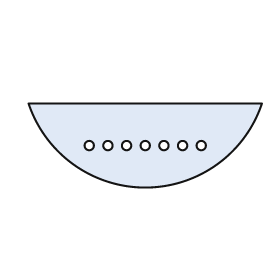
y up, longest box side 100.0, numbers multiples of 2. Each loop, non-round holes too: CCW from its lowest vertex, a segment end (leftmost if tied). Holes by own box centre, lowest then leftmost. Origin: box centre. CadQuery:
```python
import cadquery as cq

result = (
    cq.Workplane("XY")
    .moveTo(-50.0, 18.0)
    .threePointArc((0.0, -18.0), (50.0, 18.0))
    .close()
    .moveTo(-24.0, 0.0)
    .circle(2.0)
    .moveTo(-16.0, 0.0)
    .circle(2.0)
    .moveTo(-8.0, 0.0)
    .circle(2.0)
    .moveTo(0.0, 0.0)
    .circle(2.0)
    .moveTo(8.0, 0.0)
    .circle(2.0)
    .moveTo(16.0, 0.0)
    .circle(2.0)
    .moveTo(24.0, 0.0)
    .circle(2.0)
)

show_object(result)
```